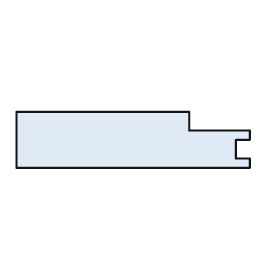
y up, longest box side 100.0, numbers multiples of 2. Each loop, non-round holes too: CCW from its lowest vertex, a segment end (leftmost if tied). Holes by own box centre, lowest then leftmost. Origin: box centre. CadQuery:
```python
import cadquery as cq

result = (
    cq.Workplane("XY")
    .moveTo(-50.0, -12.0)
    .lineTo(50.0, -12.0)
    .lineTo(50.0, -8.0)
    .lineTo(44.0, -8.0)
    .lineTo(44.0, 0.0)
    .lineTo(50.0, 0.0)
    .lineTo(50.0, 4.0)
    .lineTo(24.0, 4.0)
    .lineTo(24.0, 12.0)
    .lineTo(-50.0, 12.0)
    .close()
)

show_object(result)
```